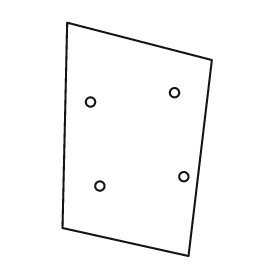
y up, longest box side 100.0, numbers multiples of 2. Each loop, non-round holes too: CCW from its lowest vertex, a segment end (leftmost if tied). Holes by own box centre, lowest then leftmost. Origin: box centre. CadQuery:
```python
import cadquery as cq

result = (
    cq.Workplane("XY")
    .moveTo(22.0, -50.0)
    .lineTo(32.0, 34.0)
    .lineTo(-30.0, 50.0)
    .lineTo(-32.0, -38.0)
    .close()
    .moveTo(-16.0, -20.0)
    .circle(2.0)
    .moveTo(20.0, -16.0)
    .circle(2.0)
    .moveTo(-20.0, 16.0)
    .circle(2.0)
    .moveTo(16.0, 20.0)
    .circle(2.0)
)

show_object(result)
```